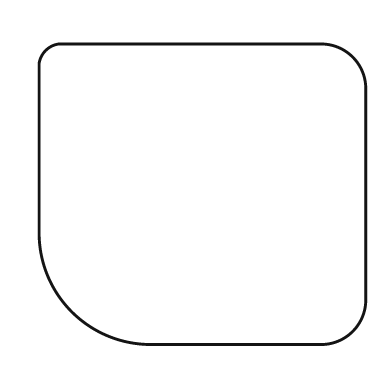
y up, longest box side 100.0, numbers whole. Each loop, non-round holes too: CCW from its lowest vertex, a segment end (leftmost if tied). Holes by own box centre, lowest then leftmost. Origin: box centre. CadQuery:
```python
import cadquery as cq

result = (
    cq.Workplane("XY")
    .moveTo(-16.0, -46.0)
    .lineTo(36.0, -46.0)
    .threePointArc((46.0, -42.0), (50.0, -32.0))
    .lineTo(50.0, 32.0)
    .threePointArc((46.0, 42.0), (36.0, 46.0))
    .lineTo(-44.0, 46.0)
    .threePointArc((-48.0, 44.0), (-50.0, 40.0))
    .lineTo(-50.0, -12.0)
    .threePointArc((-40.0, -36.0), (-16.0, -46.0))
    .close()
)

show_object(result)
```